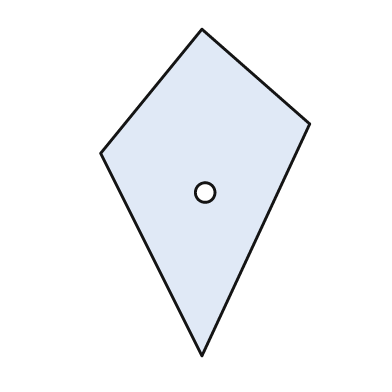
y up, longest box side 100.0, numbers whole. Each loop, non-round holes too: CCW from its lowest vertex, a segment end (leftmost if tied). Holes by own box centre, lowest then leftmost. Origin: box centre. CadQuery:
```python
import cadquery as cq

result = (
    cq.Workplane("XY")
    .moveTo(-1.0, -50.0)
    .lineTo(32.0, 21.0)
    .lineTo(-1.0, 50.0)
    .lineTo(-32.0, 12.0)
    .close()
    .moveTo(0.0, 0.0)
    .circle(3.0)
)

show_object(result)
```